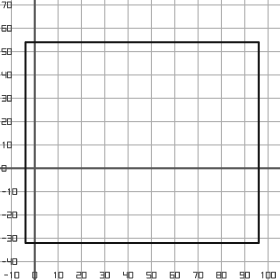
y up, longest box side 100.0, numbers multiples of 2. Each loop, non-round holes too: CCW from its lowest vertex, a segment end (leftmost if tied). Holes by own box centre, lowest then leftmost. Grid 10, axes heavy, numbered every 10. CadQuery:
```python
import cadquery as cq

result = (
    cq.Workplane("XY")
    .moveTo(-4.0, -32.0)
    .lineTo(96.0, -32.0)
    .lineTo(96.0, 54.0)
    .lineTo(-4.0, 54.0)
    .close()
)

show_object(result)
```